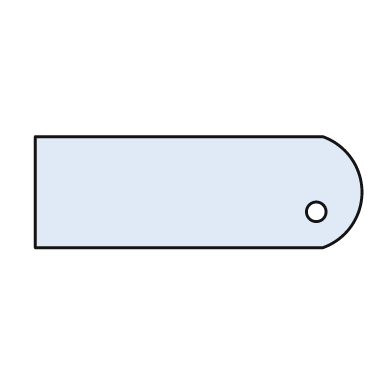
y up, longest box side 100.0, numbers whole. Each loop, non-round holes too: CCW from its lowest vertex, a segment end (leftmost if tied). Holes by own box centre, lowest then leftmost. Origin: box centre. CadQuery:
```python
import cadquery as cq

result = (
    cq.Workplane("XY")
    .moveTo(-50.0, -17.0)
    .lineTo(38.0, -17.0)
    .threePointArc((50.0, 0.0), (38.0, 17.0))
    .lineTo(-50.0, 17.0)
    .close()
    .moveTo(36.0, -6.0)
    .circle(3.0)
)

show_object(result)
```